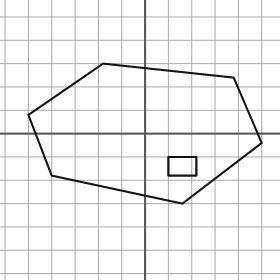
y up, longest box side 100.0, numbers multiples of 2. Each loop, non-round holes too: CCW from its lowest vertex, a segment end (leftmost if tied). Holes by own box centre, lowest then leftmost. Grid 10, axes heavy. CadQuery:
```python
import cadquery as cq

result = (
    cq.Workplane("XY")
    .moveTo(16.0, -30.0)
    .lineTo(50.0, -4.0)
    .lineTo(38.0, 24.0)
    .lineTo(-18.0, 30.0)
    .lineTo(-50.0, 8.0)
    .lineTo(-40.0, -18.0)
    .close()
    .moveTo(10.0, -18.0)
    .lineTo(22.0, -18.0)
    .lineTo(22.0, -10.0)
    .lineTo(10.0, -10.0)
    .close()
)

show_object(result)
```